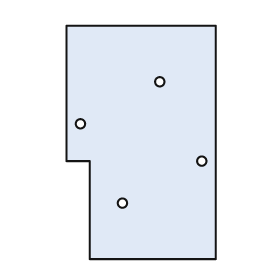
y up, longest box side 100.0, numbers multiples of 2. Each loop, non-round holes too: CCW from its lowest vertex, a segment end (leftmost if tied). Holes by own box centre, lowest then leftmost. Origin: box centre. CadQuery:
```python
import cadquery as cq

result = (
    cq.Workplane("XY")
    .moveTo(-22.0, -50.0)
    .lineTo(32.0, -50.0)
    .lineTo(32.0, 50.0)
    .lineTo(-32.0, 50.0)
    .lineTo(-32.0, -8.0)
    .lineTo(-22.0, -8.0)
    .close()
    .moveTo(-8.0, -26.0)
    .circle(2.0)
    .moveTo(26.0, -8.0)
    .circle(2.0)
    .moveTo(-26.0, 8.0)
    .circle(2.0)
    .moveTo(8.0, 26.0)
    .circle(2.0)
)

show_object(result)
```